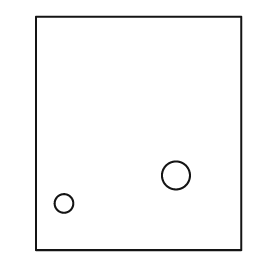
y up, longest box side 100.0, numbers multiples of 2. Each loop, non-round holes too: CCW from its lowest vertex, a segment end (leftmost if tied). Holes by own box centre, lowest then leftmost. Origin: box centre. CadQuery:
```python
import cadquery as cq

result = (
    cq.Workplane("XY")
    .moveTo(-44.0, -50.0)
    .lineTo(44.0, -50.0)
    .lineTo(44.0, 50.0)
    .lineTo(-44.0, 50.0)
    .close()
    .moveTo(-32.0, -30.0)
    .circle(4.0)
    .moveTo(16.0, -18.0)
    .circle(6.0)
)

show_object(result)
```